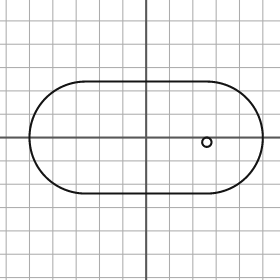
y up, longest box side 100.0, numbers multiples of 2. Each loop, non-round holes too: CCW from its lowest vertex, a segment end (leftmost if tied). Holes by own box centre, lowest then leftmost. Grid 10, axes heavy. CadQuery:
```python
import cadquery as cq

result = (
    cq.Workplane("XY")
    .moveTo(-26.0, -24.0)
    .lineTo(26.0, -24.0)
    .threePointArc((50.0, 0.0), (26.0, 24.0))
    .lineTo(-26.0, 24.0)
    .threePointArc((-50.0, 0.0), (-26.0, -24.0))
    .close()
    .moveTo(26.0, -2.0)
    .circle(2.0)
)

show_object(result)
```